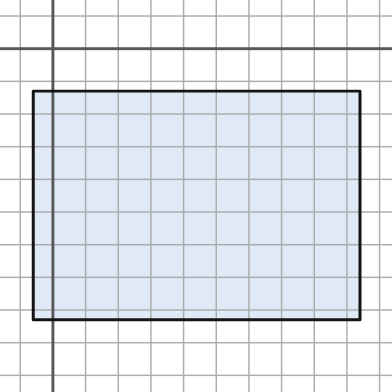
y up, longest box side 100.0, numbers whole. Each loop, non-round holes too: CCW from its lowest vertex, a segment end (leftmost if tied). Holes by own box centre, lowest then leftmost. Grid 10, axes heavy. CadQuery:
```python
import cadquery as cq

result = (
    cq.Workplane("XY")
    .moveTo(-6.0, -83.0)
    .lineTo(94.0, -83.0)
    .lineTo(94.0, -13.0)
    .lineTo(-6.0, -13.0)
    .close()
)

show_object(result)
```